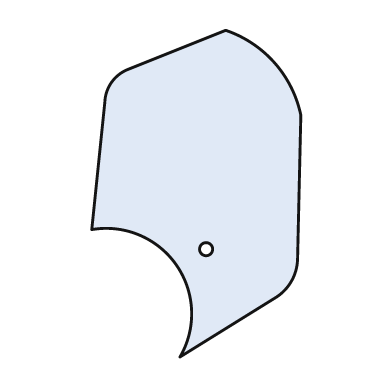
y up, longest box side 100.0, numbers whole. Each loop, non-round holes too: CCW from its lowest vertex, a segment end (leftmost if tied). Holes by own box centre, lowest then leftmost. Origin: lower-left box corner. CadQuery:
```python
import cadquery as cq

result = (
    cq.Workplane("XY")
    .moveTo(27.0, 0.0)
    .lineTo(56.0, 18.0)
    .threePointArc((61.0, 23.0), (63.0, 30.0))
    .lineTo(64.0, 74.0)
    .threePointArc((56.0, 90.0), (41.0, 100.0))
    .lineTo(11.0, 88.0)
    .threePointArc((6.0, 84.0), (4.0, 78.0))
    .lineTo(0.0, 39.0)
    .threePointArc((26.0, 28.0), (27.0, 0.0))
    .close()
    .moveTo(35.0, 33.0)
    .circle(2.0)
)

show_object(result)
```